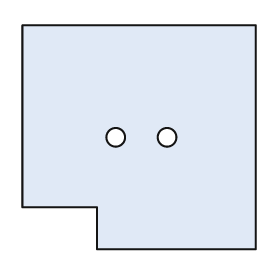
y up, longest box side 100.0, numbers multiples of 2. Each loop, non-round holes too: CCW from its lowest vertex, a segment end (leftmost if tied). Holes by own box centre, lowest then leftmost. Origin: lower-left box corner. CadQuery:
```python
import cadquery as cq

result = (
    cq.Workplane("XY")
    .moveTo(32.0, 0.0)
    .lineTo(100.0, 0.0)
    .lineTo(100.0, 96.0)
    .lineTo(0.0, 96.0)
    .lineTo(0.0, 18.0)
    .lineTo(32.0, 18.0)
    .close()
    .moveTo(40.0, 48.0)
    .circle(4.0)
    .moveTo(62.0, 48.0)
    .circle(4.0)
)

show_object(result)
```